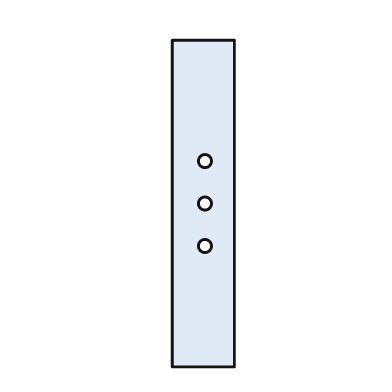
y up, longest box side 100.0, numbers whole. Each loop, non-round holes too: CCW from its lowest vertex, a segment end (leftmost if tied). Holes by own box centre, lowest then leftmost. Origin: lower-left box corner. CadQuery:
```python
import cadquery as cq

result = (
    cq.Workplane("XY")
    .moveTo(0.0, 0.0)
    .lineTo(19.0, 0.0)
    .lineTo(19.0, 100.0)
    .lineTo(0.0, 100.0)
    .close()
    .moveTo(10.0, 37.0)
    .circle(2.0)
    .moveTo(10.0, 50.0)
    .circle(2.0)
    .moveTo(10.0, 63.0)
    .circle(2.0)
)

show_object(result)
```